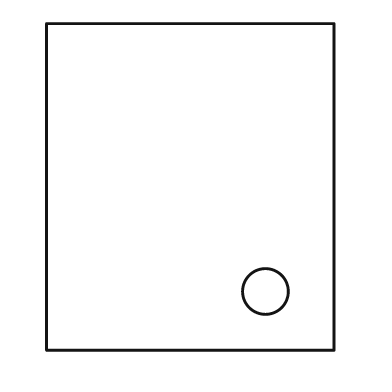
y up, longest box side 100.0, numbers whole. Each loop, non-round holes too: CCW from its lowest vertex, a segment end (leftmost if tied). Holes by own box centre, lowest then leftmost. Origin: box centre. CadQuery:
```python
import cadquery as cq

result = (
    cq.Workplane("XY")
    .moveTo(-44.0, -50.0)
    .lineTo(44.0, -50.0)
    .lineTo(44.0, 50.0)
    .lineTo(-44.0, 50.0)
    .close()
    .moveTo(23.0, -32.0)
    .circle(7.0)
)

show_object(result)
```